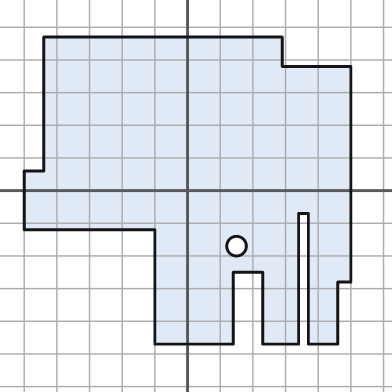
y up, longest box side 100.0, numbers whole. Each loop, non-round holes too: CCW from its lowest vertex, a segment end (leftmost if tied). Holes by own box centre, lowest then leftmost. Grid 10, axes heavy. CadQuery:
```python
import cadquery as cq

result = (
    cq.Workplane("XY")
    .moveTo(-10.0, -47.0)
    .lineTo(14.0, -47.0)
    .lineTo(14.0, -25.0)
    .lineTo(23.0, -25.0)
    .lineTo(23.0, -47.0)
    .lineTo(34.0, -47.0)
    .lineTo(34.0, -7.0)
    .lineTo(37.0, -7.0)
    .lineTo(37.0, -47.0)
    .lineTo(46.0, -47.0)
    .lineTo(46.0, -28.0)
    .lineTo(50.0, -28.0)
    .lineTo(50.0, 38.0)
    .lineTo(29.0, 38.0)
    .lineTo(29.0, 47.0)
    .lineTo(-44.0, 47.0)
    .lineTo(-44.0, 6.0)
    .lineTo(-50.0, 6.0)
    .lineTo(-50.0, -12.0)
    .lineTo(-10.0, -12.0)
    .close()
    .moveTo(15.0, -17.0)
    .circle(3.0)
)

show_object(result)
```